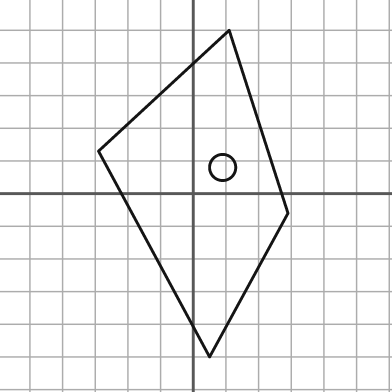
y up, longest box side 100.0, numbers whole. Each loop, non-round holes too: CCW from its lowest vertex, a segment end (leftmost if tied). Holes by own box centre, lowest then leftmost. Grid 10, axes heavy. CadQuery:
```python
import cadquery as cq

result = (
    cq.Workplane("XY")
    .moveTo(5.0, -50.0)
    .lineTo(29.0, -6.0)
    .lineTo(11.0, 50.0)
    .lineTo(-29.0, 13.0)
    .close()
    .moveTo(9.0, 8.0)
    .circle(4.0)
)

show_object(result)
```